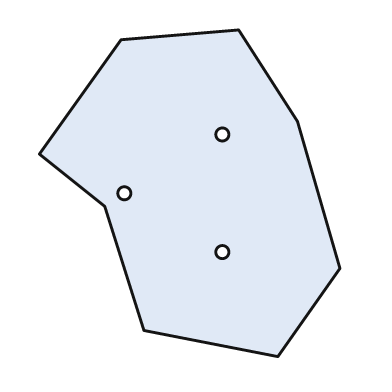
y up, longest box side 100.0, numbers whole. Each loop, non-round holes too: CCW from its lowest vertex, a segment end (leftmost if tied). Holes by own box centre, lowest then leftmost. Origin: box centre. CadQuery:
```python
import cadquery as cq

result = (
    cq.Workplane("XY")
    .moveTo(27.0, -50.0)
    .lineTo(46.0, -23.0)
    .lineTo(33.0, 22.0)
    .lineTo(15.0, 50.0)
    .lineTo(-21.0, 47.0)
    .lineTo(-46.0, 12.0)
    .lineTo(-26.0, -4.0)
    .lineTo(-14.0, -42.0)
    .close()
    .moveTo(10.0, -18.0)
    .circle(2.0)
    .moveTo(-20.0, 0.0)
    .circle(2.0)
    .moveTo(10.0, 18.0)
    .circle(2.0)
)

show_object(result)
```